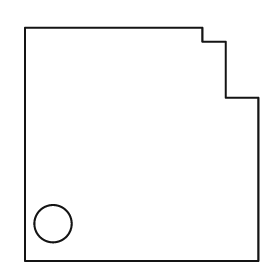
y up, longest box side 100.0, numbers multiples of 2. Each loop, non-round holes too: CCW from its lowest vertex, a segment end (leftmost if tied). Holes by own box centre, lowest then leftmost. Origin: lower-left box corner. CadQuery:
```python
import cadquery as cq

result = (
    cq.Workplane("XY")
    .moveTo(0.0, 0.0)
    .lineTo(100.0, 0.0)
    .lineTo(100.0, 70.0)
    .lineTo(86.0, 70.0)
    .lineTo(86.0, 94.0)
    .lineTo(76.0, 94.0)
    .lineTo(76.0, 100.0)
    .lineTo(0.0, 100.0)
    .close()
    .moveTo(12.0, 16.0)
    .circle(8.0)
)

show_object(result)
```